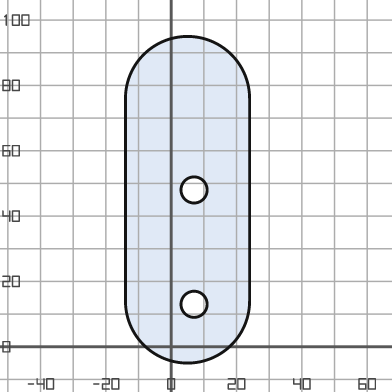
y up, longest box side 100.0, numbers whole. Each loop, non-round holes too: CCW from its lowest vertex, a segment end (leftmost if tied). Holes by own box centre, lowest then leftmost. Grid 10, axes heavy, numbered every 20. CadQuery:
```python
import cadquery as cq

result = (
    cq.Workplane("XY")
    .moveTo(-14.0, 14.0)
    .threePointArc((5.0, -5.0), (24.0, 14.0))
    .lineTo(24.0, 76.0)
    .threePointArc((5.0, 95.0), (-14.0, 76.0))
    .close()
    .moveTo(7.0, 13.0)
    .circle(4.0)
    .moveTo(7.0, 48.0)
    .circle(4.0)
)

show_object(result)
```